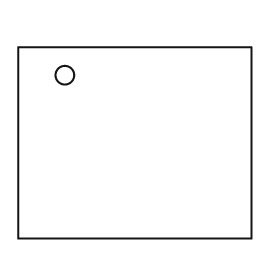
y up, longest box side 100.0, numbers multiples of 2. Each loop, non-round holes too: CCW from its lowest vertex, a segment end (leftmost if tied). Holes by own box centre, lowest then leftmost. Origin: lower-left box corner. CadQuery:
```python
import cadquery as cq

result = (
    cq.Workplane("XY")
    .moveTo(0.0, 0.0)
    .lineTo(100.0, 0.0)
    .lineTo(100.0, 82.0)
    .lineTo(0.0, 82.0)
    .close()
    .moveTo(20.0, 70.0)
    .circle(4.0)
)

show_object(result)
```